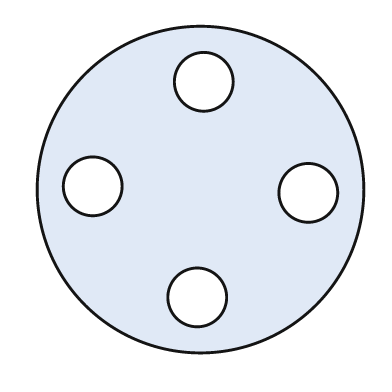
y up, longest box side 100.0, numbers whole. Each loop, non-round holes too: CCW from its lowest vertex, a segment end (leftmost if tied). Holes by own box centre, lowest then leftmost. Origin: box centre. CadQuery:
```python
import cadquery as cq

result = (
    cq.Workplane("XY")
    .moveTo(0.0, 0.0)
    .circle(50.0)
    .moveTo(-1.0, -33.0)
    .circle(9.0)
    .moveTo(33.0, -1.0)
    .circle(9.0)
    .moveTo(-33.0, 1.0)
    .circle(9.0)
    .moveTo(1.0, 33.0)
    .circle(9.0)
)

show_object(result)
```